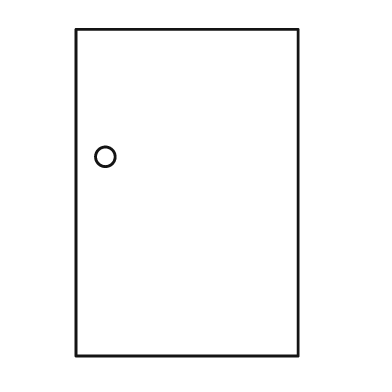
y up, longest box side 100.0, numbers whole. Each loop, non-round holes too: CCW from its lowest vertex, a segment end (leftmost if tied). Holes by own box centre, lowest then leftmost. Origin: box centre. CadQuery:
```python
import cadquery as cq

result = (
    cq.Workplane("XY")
    .moveTo(-34.0, -50.0)
    .lineTo(34.0, -50.0)
    .lineTo(34.0, 50.0)
    .lineTo(-34.0, 50.0)
    .close()
    .moveTo(-25.0, 11.0)
    .circle(3.0)
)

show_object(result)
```